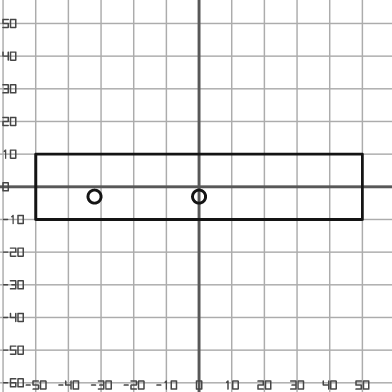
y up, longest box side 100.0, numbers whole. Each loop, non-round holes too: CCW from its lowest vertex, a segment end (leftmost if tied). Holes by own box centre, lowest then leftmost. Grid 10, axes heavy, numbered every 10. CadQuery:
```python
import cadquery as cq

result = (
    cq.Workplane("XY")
    .moveTo(-50.0, -10.0)
    .lineTo(50.0, -10.0)
    .lineTo(50.0, 10.0)
    .lineTo(-50.0, 10.0)
    .close()
    .moveTo(-32.0, -3.0)
    .circle(2.0)
    .moveTo(0.0, -3.0)
    .circle(2.0)
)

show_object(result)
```